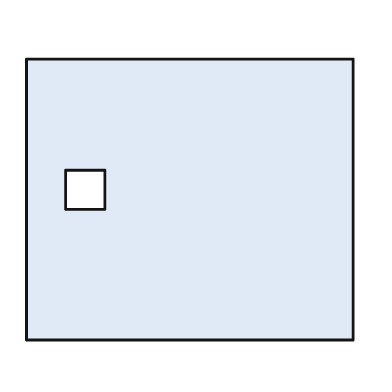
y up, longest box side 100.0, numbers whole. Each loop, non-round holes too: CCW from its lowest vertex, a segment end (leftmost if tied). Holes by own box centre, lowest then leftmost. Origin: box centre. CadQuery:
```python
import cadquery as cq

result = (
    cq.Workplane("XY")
    .moveTo(-50.0, -43.0)
    .lineTo(50.0, -43.0)
    .lineTo(50.0, 43.0)
    .lineTo(-50.0, 43.0)
    .close()
    .moveTo(-38.0, -3.0)
    .lineTo(-26.0, -3.0)
    .lineTo(-26.0, 9.0)
    .lineTo(-38.0, 9.0)
    .close()
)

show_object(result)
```